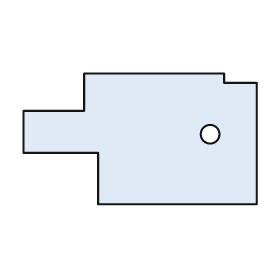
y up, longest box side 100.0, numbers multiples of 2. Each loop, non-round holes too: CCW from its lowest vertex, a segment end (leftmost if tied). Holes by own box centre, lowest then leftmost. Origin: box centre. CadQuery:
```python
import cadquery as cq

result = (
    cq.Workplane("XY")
    .moveTo(-18.0, -28.0)
    .lineTo(50.0, -28.0)
    .lineTo(50.0, 24.0)
    .lineTo(36.0, 24.0)
    .lineTo(36.0, 28.0)
    .lineTo(-24.0, 28.0)
    .lineTo(-24.0, 12.0)
    .lineTo(-50.0, 12.0)
    .lineTo(-50.0, -6.0)
    .lineTo(-18.0, -6.0)
    .close()
    .moveTo(30.0, 2.0)
    .circle(4.0)
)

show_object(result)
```